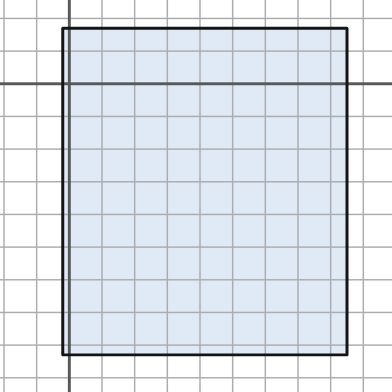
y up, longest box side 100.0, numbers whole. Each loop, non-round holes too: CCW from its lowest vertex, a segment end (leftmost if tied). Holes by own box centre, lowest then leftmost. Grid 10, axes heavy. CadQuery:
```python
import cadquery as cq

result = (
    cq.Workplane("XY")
    .moveTo(-2.0, -83.0)
    .lineTo(85.0, -83.0)
    .lineTo(85.0, 17.0)
    .lineTo(-2.0, 17.0)
    .close()
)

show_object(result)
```